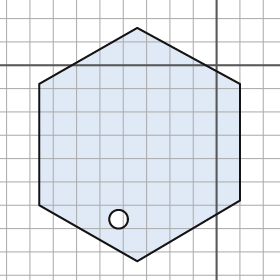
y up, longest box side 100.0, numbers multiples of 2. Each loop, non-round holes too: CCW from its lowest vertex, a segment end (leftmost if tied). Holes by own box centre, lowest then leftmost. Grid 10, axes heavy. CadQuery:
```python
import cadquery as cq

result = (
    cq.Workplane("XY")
    .moveTo(-34.0, -84.0)
    .lineTo(10.0, -58.0)
    .lineTo(10.0, -8.0)
    .lineTo(-34.0, 16.0)
    .lineTo(-76.0, -8.0)
    .lineTo(-76.0, -60.0)
    .close()
    .moveTo(-42.0, -66.0)
    .circle(4.0)
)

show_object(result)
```